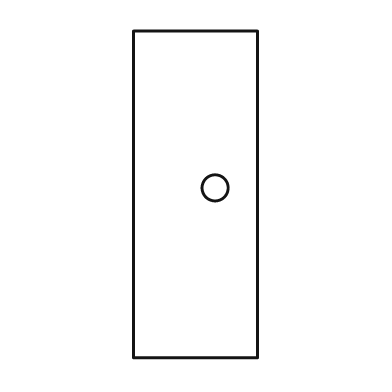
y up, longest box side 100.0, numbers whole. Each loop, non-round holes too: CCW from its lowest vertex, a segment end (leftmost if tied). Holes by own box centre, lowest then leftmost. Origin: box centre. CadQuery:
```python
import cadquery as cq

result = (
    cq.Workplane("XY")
    .moveTo(-19.0, -50.0)
    .lineTo(19.0, -50.0)
    .lineTo(19.0, 50.0)
    .lineTo(-19.0, 50.0)
    .close()
    .moveTo(6.0, 2.0)
    .circle(4.0)
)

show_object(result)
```